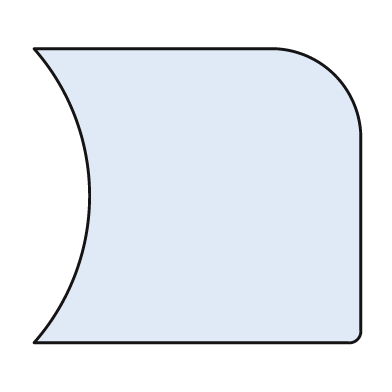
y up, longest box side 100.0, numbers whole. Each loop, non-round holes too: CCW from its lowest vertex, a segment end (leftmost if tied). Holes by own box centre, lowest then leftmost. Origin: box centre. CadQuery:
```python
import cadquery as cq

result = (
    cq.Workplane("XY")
    .moveTo(-50.0, -45.0)
    .lineTo(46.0, -45.0)
    .threePointArc((49.0, -44.0), (50.0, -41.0))
    .lineTo(50.0, 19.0)
    .threePointArc((42.0, 37.0), (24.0, 45.0))
    .lineTo(-50.0, 45.0)
    .threePointArc((-33.0, 0.0), (-50.0, -45.0))
    .close()
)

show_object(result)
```